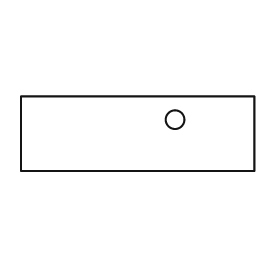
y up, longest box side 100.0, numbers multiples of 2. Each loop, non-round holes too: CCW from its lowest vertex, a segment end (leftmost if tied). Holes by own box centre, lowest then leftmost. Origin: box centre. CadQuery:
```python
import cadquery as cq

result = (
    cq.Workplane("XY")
    .moveTo(-50.0, -16.0)
    .lineTo(50.0, -16.0)
    .lineTo(50.0, 16.0)
    .lineTo(-50.0, 16.0)
    .close()
    .moveTo(16.0, 6.0)
    .circle(4.0)
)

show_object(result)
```